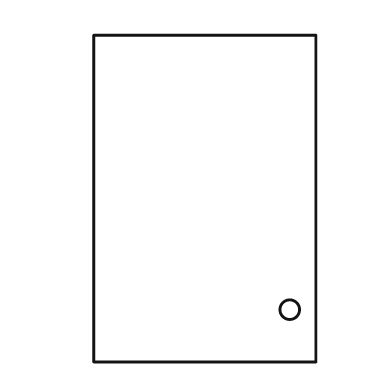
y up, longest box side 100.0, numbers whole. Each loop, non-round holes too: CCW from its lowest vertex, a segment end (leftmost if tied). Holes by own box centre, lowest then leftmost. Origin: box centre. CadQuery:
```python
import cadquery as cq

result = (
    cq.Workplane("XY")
    .moveTo(-34.0, -50.0)
    .lineTo(34.0, -50.0)
    .lineTo(34.0, 50.0)
    .lineTo(-34.0, 50.0)
    .close()
    .moveTo(26.0, -34.0)
    .circle(3.0)
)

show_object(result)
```